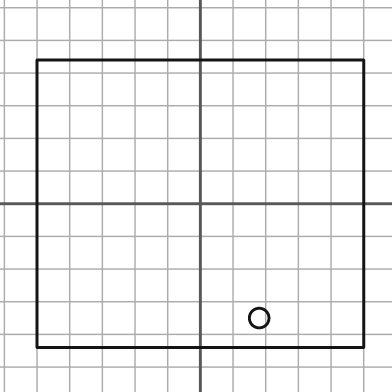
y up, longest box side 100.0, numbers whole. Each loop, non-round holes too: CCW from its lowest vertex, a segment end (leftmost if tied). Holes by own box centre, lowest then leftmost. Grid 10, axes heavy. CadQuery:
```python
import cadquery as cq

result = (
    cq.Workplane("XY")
    .moveTo(-50.0, -44.0)
    .lineTo(50.0, -44.0)
    .lineTo(50.0, 44.0)
    .lineTo(-50.0, 44.0)
    .close()
    .moveTo(18.0, -35.0)
    .circle(3.0)
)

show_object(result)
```